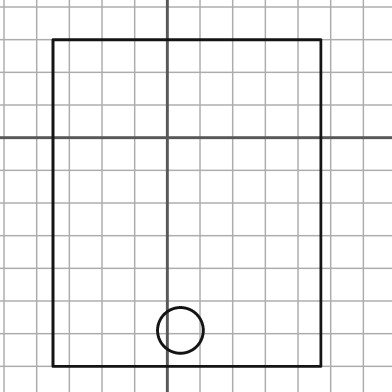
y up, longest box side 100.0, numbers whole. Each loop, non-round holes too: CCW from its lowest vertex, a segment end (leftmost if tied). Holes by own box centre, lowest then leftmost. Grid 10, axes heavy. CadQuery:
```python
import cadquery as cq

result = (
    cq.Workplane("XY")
    .moveTo(-35.0, -70.0)
    .lineTo(47.0, -70.0)
    .lineTo(47.0, 30.0)
    .lineTo(-35.0, 30.0)
    .close()
    .moveTo(4.0, -59.0)
    .circle(7.0)
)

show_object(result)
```